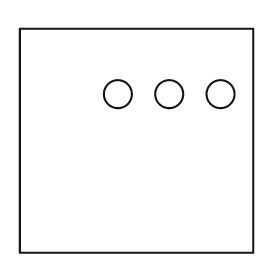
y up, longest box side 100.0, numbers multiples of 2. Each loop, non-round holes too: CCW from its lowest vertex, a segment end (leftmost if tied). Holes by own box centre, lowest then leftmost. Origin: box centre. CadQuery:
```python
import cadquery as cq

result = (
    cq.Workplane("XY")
    .moveTo(-50.0, -48.0)
    .lineTo(50.0, -48.0)
    .lineTo(50.0, 48.0)
    .lineTo(-50.0, 48.0)
    .close()
    .moveTo(-8.0, 20.0)
    .circle(6.0)
    .moveTo(14.0, 20.0)
    .circle(6.0)
    .moveTo(36.0, 20.0)
    .circle(6.0)
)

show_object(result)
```